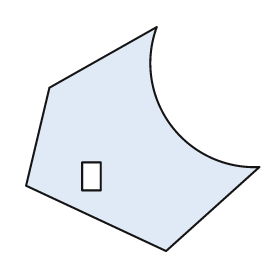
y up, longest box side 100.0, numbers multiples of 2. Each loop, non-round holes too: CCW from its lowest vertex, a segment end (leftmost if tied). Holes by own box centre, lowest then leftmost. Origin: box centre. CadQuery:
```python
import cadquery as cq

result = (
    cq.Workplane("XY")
    .moveTo(10.0, -48.0)
    .lineTo(50.0, -12.0)
    .threePointArc((12.0, 6.0), (6.0, 48.0))
    .lineTo(-40.0, 22.0)
    .lineTo(-50.0, -20.0)
    .close()
    .moveTo(-26.0, -22.0)
    .lineTo(-18.0, -22.0)
    .lineTo(-18.0, -10.0)
    .lineTo(-26.0, -10.0)
    .close()
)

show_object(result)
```